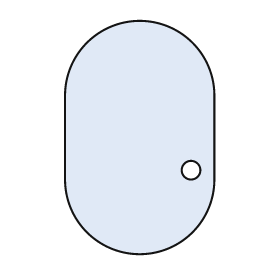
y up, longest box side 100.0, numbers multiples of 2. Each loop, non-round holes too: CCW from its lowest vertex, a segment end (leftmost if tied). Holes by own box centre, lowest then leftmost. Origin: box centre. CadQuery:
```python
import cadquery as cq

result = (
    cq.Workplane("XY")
    .moveTo(-32.0, -18.0)
    .threePointArc((0.0, -50.0), (32.0, -18.0))
    .lineTo(32.0, 18.0)
    .threePointArc((0.0, 50.0), (-32.0, 18.0))
    .close()
    .moveTo(22.0, -14.0)
    .circle(4.0)
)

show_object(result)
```